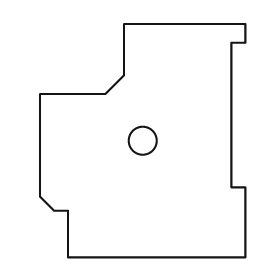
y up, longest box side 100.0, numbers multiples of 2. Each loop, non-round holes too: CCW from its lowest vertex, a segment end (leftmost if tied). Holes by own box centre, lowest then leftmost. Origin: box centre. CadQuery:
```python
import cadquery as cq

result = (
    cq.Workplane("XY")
    .moveTo(-32.0, -50.0)
    .lineTo(44.0, -50.0)
    .lineTo(44.0, -20.0)
    .lineTo(38.0, -20.0)
    .lineTo(38.0, 42.0)
    .lineTo(44.0, 42.0)
    .lineTo(44.0, 50.0)
    .lineTo(-8.0, 50.0)
    .lineTo(-8.0, 28.0)
    .lineTo(-16.0, 20.0)
    .lineTo(-44.0, 20.0)
    .lineTo(-44.0, -24.0)
    .lineTo(-38.0, -30.0)
    .lineTo(-32.0, -30.0)
    .close()
    .moveTo(0.0, 0.0)
    .circle(6.0)
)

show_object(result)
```